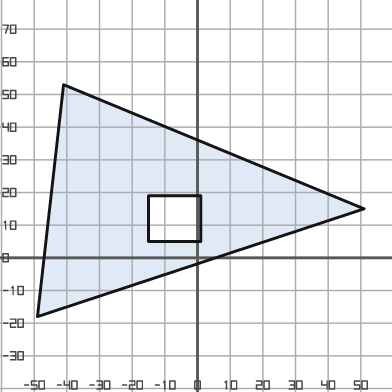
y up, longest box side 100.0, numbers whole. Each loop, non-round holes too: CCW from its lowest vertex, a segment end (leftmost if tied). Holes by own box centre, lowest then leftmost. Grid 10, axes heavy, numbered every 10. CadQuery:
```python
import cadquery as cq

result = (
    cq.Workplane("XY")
    .moveTo(-49.0, -18.0)
    .lineTo(51.0, 15.0)
    .lineTo(-41.0, 53.0)
    .close()
    .moveTo(-15.0, 5.0)
    .lineTo(1.0, 5.0)
    .lineTo(1.0, 19.0)
    .lineTo(-15.0, 19.0)
    .close()
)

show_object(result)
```